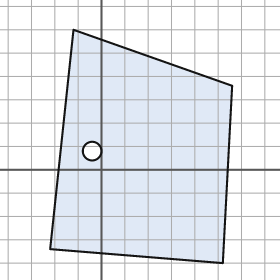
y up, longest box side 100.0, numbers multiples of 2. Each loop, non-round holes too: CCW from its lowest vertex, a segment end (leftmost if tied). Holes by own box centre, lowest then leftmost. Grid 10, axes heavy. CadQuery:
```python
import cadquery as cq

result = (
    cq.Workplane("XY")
    .moveTo(52.0, -40.0)
    .lineTo(56.0, 36.0)
    .lineTo(-12.0, 60.0)
    .lineTo(-22.0, -34.0)
    .close()
    .moveTo(-4.0, 8.0)
    .circle(4.0)
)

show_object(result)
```